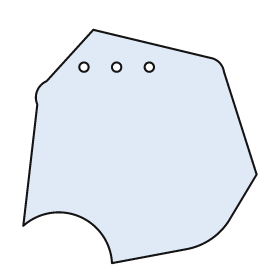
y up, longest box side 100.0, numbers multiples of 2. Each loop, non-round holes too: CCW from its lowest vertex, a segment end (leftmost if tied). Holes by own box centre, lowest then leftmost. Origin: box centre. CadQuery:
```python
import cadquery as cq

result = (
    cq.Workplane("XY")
    .moveTo(-12.0, -50.0)
    .lineTo(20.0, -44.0)
    .threePointArc((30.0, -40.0), (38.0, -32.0))
    .lineTo(50.0, -12.0)
    .lineTo(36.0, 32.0)
    .threePointArc((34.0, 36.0), (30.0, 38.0))
    .lineTo(-20.0, 50.0)
    .lineTo(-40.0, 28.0)
    .threePointArc((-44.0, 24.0), (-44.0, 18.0))
    .lineTo(-50.0, -34.0)
    .threePointArc((-26.0, -30.0), (-12.0, -50.0))
    .close()
    .moveTo(-24.0, 34.0)
    .circle(2.0)
    .moveTo(-10.0, 34.0)
    .circle(2.0)
    .moveTo(4.0, 34.0)
    .circle(2.0)
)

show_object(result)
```